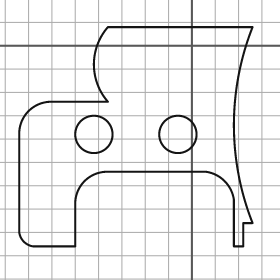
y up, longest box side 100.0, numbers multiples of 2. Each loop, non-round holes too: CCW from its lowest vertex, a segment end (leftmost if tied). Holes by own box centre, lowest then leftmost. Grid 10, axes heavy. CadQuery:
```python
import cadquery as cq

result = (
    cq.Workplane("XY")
    .moveTo(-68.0, -86.0)
    .lineTo(-50.0, -86.0)
    .lineTo(-50.0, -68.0)
    .threePointArc((-46.0, -58.0), (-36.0, -54.0))
    .lineTo(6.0, -54.0)
    .threePointArc((14.0, -58.0), (18.0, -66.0))
    .lineTo(18.0, -86.0)
    .lineTo(22.0, -86.0)
    .lineTo(22.0, -76.0)
    .lineTo(26.0, -76.0)
    .threePointArc((18.0, -34.0), (26.0, 8.0))
    .lineTo(-36.0, 8.0)
    .threePointArc((-42.0, -8.0), (-36.0, -24.0))
    .lineTo(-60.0, -24.0)
    .threePointArc((-70.0, -28.0), (-74.0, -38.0))
    .lineTo(-74.0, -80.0)
    .threePointArc((-72.0, -84.0), (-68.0, -86.0))
    .close()
    .moveTo(-42.0, -38.0)
    .circle(8.0)
    .moveTo(-6.0, -38.0)
    .circle(8.0)
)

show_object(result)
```